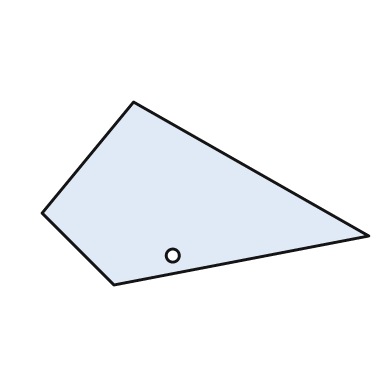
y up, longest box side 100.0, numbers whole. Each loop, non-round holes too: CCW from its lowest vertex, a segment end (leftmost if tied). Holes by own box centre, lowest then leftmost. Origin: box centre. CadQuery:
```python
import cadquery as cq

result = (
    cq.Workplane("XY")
    .moveTo(-28.0, -28.0)
    .lineTo(50.0, -13.0)
    .lineTo(-22.0, 28.0)
    .lineTo(-50.0, -6.0)
    .close()
    .moveTo(-10.0, -19.0)
    .circle(2.0)
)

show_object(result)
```